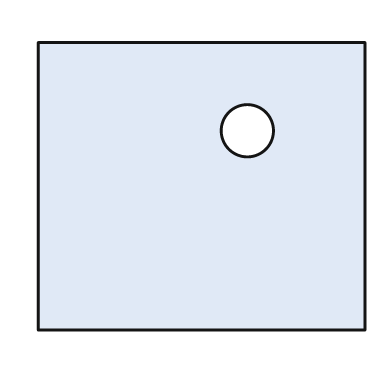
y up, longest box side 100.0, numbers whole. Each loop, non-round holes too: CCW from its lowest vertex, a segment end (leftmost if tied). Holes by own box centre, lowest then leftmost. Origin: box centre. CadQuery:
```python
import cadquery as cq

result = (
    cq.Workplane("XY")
    .moveTo(-50.0, -44.0)
    .lineTo(50.0, -44.0)
    .lineTo(50.0, 44.0)
    .lineTo(-50.0, 44.0)
    .close()
    .moveTo(14.0, 17.0)
    .circle(8.0)
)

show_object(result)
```